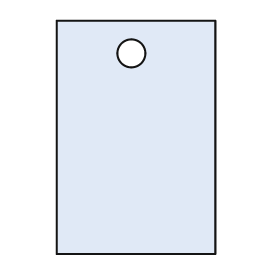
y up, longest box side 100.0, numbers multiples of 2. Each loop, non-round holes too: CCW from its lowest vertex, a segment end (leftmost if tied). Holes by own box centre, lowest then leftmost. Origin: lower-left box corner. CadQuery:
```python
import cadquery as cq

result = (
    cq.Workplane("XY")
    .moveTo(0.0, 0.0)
    .lineTo(68.0, 0.0)
    .lineTo(68.0, 100.0)
    .lineTo(0.0, 100.0)
    .close()
    .moveTo(32.0, 86.0)
    .circle(6.0)
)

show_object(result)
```